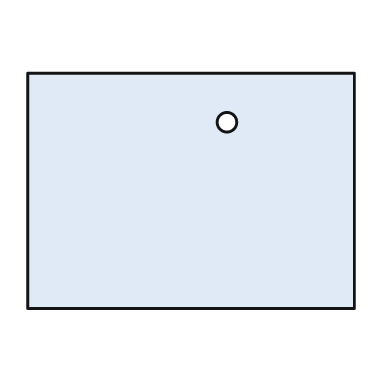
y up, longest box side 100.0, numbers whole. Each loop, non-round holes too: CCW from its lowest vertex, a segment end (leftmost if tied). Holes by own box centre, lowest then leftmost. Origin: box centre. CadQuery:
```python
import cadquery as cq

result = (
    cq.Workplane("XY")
    .moveTo(-50.0, -36.0)
    .lineTo(50.0, -36.0)
    .lineTo(50.0, 36.0)
    .lineTo(-50.0, 36.0)
    .close()
    .moveTo(11.0, 21.0)
    .circle(3.0)
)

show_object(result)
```